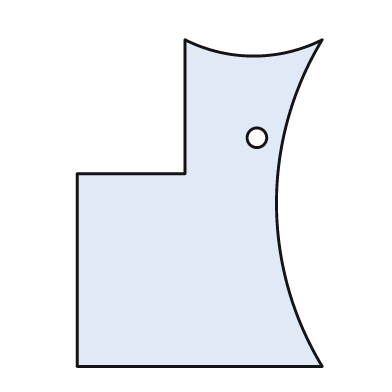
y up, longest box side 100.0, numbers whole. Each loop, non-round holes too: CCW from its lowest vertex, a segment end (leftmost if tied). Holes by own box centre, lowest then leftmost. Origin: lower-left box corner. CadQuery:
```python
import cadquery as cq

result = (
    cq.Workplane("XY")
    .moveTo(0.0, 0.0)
    .lineTo(75.0, 0.0)
    .threePointArc((61.0, 50.0), (75.0, 100.0))
    .threePointArc((54.0, 95.0), (33.0, 100.0))
    .lineTo(33.0, 59.0)
    .lineTo(0.0, 59.0)
    .close()
    .moveTo(55.0, 70.0)
    .circle(3.0)
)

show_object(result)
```